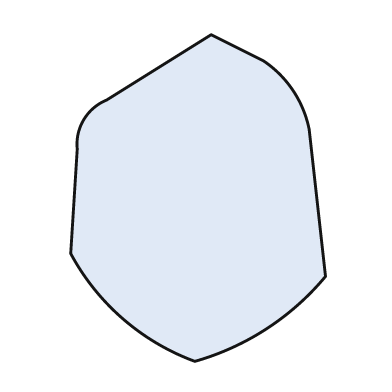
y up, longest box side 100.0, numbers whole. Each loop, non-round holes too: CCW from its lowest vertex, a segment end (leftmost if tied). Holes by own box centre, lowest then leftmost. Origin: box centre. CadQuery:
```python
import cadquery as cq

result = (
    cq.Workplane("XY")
    .moveTo(-1.0, -50.0)
    .threePointArc((21.0, -40.0), (39.0, -24.0))
    .lineTo(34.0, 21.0)
    .threePointArc((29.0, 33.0), (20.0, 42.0))
    .lineTo(4.0, 50.0)
    .lineTo(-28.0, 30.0)
    .threePointArc((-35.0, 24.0), (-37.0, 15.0))
    .lineTo(-39.0, -17.0)
    .threePointArc((-23.0, -37.0), (-1.0, -50.0))
    .close()
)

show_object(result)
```